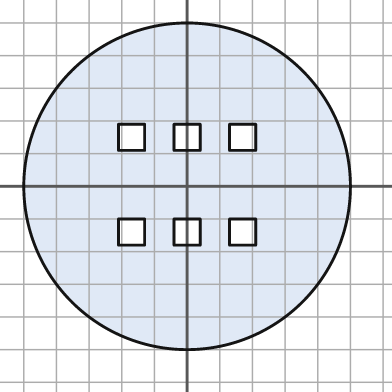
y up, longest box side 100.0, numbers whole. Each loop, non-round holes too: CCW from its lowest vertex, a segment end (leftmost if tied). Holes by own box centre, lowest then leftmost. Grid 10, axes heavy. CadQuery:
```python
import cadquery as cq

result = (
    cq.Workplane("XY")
    .moveTo(0.0, 0.0)
    .circle(50.0)
    .moveTo(-21.0, -18.0)
    .lineTo(-13.0, -18.0)
    .lineTo(-13.0, -10.0)
    .lineTo(-21.0, -10.0)
    .close()
    .moveTo(-4.0, -18.0)
    .lineTo(4.0, -18.0)
    .lineTo(4.0, -10.0)
    .lineTo(-4.0, -10.0)
    .close()
    .moveTo(13.0, -18.0)
    .lineTo(21.0, -18.0)
    .lineTo(21.0, -10.0)
    .lineTo(13.0, -10.0)
    .close()
    .moveTo(-21.0, 11.0)
    .lineTo(-13.0, 11.0)
    .lineTo(-13.0, 19.0)
    .lineTo(-21.0, 19.0)
    .close()
    .moveTo(-4.0, 11.0)
    .lineTo(4.0, 11.0)
    .lineTo(4.0, 19.0)
    .lineTo(-4.0, 19.0)
    .close()
    .moveTo(13.0, 11.0)
    .lineTo(21.0, 11.0)
    .lineTo(21.0, 19.0)
    .lineTo(13.0, 19.0)
    .close()
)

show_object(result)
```